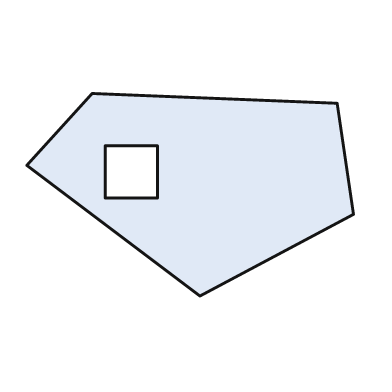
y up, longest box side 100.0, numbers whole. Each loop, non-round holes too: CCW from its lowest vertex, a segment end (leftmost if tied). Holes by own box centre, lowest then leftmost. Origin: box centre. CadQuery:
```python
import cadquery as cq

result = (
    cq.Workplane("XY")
    .moveTo(3.0, -31.0)
    .lineTo(50.0, -6.0)
    .lineTo(45.0, 28.0)
    .lineTo(-30.0, 31.0)
    .lineTo(-50.0, 9.0)
    .close()
    .moveTo(-26.0, -1.0)
    .lineTo(-10.0, -1.0)
    .lineTo(-10.0, 15.0)
    .lineTo(-26.0, 15.0)
    .close()
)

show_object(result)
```